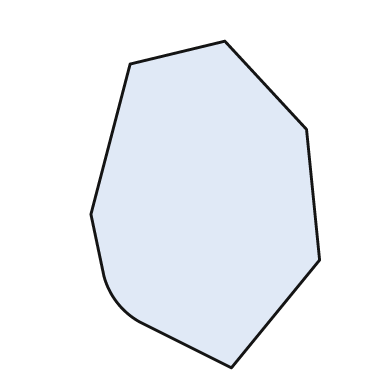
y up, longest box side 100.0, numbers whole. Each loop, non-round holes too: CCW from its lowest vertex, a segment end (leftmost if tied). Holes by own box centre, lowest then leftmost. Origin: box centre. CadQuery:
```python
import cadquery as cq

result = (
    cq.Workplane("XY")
    .moveTo(8.0, -50.0)
    .lineTo(35.0, -17.0)
    .lineTo(31.0, 23.0)
    .lineTo(6.0, 50.0)
    .lineTo(-23.0, 43.0)
    .lineTo(-35.0, -3.0)
    .lineTo(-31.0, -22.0)
    .threePointArc((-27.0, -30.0), (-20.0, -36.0))
    .close()
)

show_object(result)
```